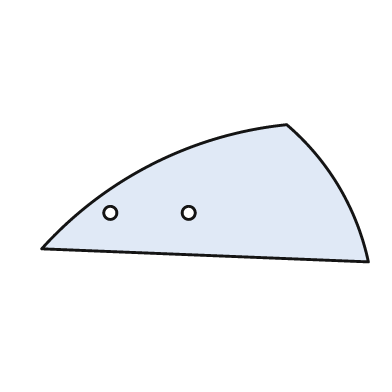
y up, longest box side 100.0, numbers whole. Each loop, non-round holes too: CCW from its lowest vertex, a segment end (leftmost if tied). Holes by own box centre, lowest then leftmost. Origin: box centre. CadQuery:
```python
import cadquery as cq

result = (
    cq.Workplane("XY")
    .moveTo(50.0, -21.0)
    .threePointArc((41.0, 2.0), (25.0, 21.0))
    .threePointArc((-16.0, 9.0), (-50.0, -17.0))
    .close()
    .moveTo(-29.0, -6.0)
    .circle(2.0)
    .moveTo(-5.0, -6.0)
    .circle(2.0)
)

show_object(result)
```